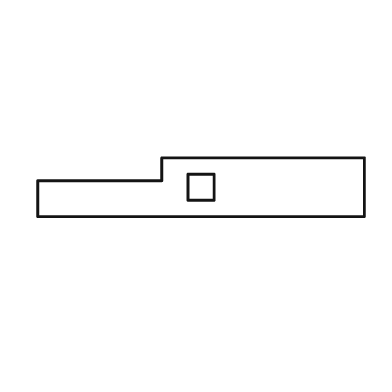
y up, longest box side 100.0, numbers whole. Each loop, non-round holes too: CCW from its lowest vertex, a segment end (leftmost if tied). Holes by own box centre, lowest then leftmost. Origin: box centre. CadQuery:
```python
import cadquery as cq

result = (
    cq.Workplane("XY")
    .moveTo(-50.0, -9.0)
    .lineTo(50.0, -9.0)
    .lineTo(50.0, 9.0)
    .lineTo(-12.0, 9.0)
    .lineTo(-12.0, 2.0)
    .lineTo(-50.0, 2.0)
    .close()
    .moveTo(-4.0, -4.0)
    .lineTo(4.0, -4.0)
    .lineTo(4.0, 4.0)
    .lineTo(-4.0, 4.0)
    .close()
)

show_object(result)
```